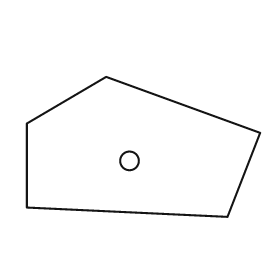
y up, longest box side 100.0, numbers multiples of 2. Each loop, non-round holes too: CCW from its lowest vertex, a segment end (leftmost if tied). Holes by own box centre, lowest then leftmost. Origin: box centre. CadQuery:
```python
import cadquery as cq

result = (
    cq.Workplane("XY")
    .moveTo(36.0, -30.0)
    .lineTo(50.0, 6.0)
    .lineTo(-16.0, 30.0)
    .lineTo(-50.0, 10.0)
    .lineTo(-50.0, -26.0)
    .close()
    .moveTo(-6.0, -6.0)
    .circle(4.0)
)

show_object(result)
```